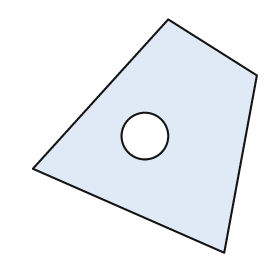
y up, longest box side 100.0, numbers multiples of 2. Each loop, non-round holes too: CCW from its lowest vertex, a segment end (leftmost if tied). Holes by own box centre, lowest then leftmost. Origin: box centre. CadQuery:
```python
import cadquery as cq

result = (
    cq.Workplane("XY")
    .moveTo(34.0, -50.0)
    .lineTo(48.0, 26.0)
    .lineTo(10.0, 50.0)
    .lineTo(-48.0, -14.0)
    .close()
    .moveTo(0.0, 0.0)
    .circle(10.0)
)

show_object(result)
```